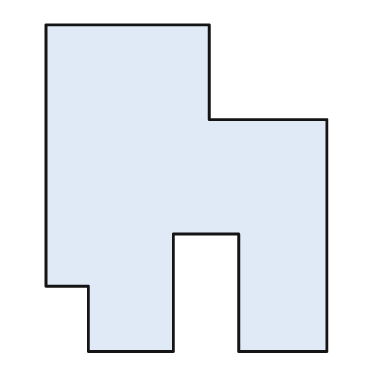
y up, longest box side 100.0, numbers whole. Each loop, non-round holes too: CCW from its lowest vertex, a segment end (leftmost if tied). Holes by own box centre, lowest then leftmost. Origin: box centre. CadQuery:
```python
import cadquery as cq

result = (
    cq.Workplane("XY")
    .moveTo(-30.0, -50.0)
    .lineTo(-4.0, -50.0)
    .lineTo(-4.0, -14.0)
    .lineTo(16.0, -14.0)
    .lineTo(16.0, -50.0)
    .lineTo(43.0, -50.0)
    .lineTo(43.0, 21.0)
    .lineTo(7.0, 21.0)
    .lineTo(7.0, 50.0)
    .lineTo(-43.0, 50.0)
    .lineTo(-43.0, -30.0)
    .lineTo(-30.0, -30.0)
    .close()
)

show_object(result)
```